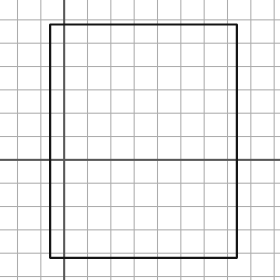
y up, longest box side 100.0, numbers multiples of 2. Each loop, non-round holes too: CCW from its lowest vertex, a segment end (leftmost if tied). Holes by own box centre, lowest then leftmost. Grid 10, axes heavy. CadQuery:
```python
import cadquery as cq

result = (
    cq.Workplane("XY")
    .moveTo(-6.0, -42.0)
    .lineTo(74.0, -42.0)
    .lineTo(74.0, 58.0)
    .lineTo(-6.0, 58.0)
    .close()
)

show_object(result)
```